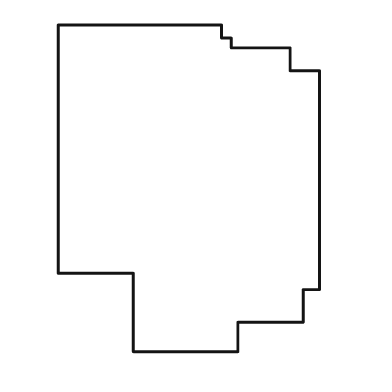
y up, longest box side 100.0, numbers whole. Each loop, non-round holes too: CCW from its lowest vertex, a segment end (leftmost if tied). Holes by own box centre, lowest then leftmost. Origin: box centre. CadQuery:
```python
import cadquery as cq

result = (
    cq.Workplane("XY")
    .moveTo(-17.0, -50.0)
    .lineTo(15.0, -50.0)
    .lineTo(15.0, -41.0)
    .lineTo(35.0, -41.0)
    .lineTo(35.0, -31.0)
    .lineTo(40.0, -31.0)
    .lineTo(40.0, 36.0)
    .lineTo(31.0, 36.0)
    .lineTo(31.0, 43.0)
    .lineTo(13.0, 43.0)
    .lineTo(13.0, 46.0)
    .lineTo(10.0, 46.0)
    .lineTo(10.0, 50.0)
    .lineTo(-40.0, 50.0)
    .lineTo(-40.0, -26.0)
    .lineTo(-17.0, -26.0)
    .close()
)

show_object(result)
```